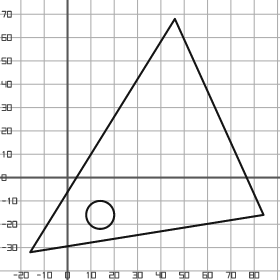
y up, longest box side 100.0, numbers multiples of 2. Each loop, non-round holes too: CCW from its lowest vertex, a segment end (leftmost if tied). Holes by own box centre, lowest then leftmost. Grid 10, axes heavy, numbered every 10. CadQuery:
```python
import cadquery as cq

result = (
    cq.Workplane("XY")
    .moveTo(-16.0, -32.0)
    .lineTo(84.0, -16.0)
    .lineTo(46.0, 68.0)
    .close()
    .moveTo(14.0, -16.0)
    .circle(6.0)
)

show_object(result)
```